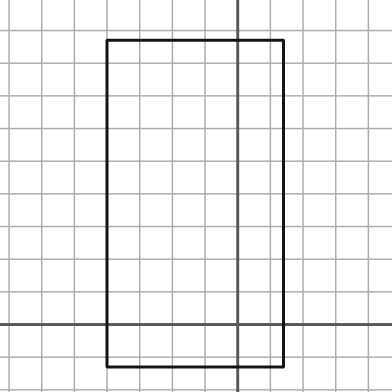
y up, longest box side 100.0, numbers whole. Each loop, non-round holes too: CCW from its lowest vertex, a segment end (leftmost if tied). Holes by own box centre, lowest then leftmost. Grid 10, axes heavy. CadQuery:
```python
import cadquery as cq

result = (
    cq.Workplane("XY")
    .moveTo(-40.0, -13.0)
    .lineTo(14.0, -13.0)
    .lineTo(14.0, 87.0)
    .lineTo(-40.0, 87.0)
    .close()
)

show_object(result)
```